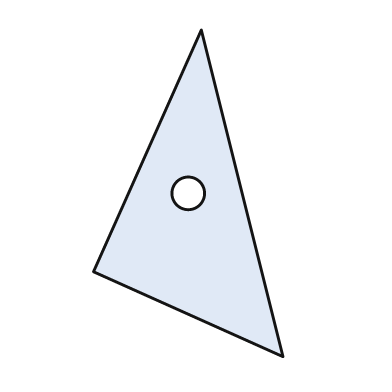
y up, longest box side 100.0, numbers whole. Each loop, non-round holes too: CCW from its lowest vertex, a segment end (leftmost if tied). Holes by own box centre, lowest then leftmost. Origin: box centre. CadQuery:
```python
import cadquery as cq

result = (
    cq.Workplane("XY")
    .moveTo(29.0, -50.0)
    .lineTo(4.0, 50.0)
    .lineTo(-29.0, -24.0)
    .close()
    .moveTo(0.0, 0.0)
    .circle(5.0)
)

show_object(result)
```